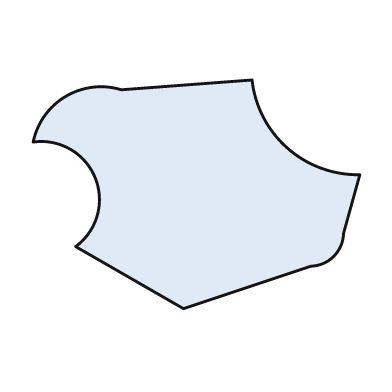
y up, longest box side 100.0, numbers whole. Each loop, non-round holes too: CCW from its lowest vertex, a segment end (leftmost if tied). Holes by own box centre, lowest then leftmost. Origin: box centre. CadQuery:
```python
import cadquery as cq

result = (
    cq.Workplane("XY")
    .moveTo(-4.0, -35.0)
    .lineTo(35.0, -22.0)
    .threePointArc((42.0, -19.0), (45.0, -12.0))
    .lineTo(50.0, 6.0)
    .threePointArc((28.0, 14.0), (17.0, 35.0))
    .lineTo(-23.0, 32.0)
    .threePointArc((-40.0, 30.0), (-50.0, 16.0))
    .threePointArc((-31.0, 5.0), (-37.0, -16.0))
    .close()
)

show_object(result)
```